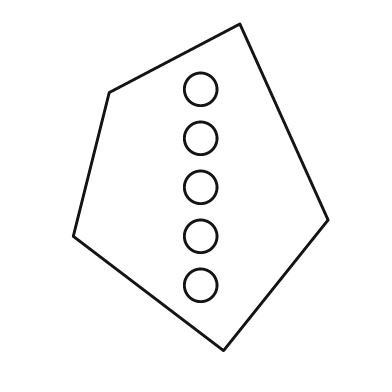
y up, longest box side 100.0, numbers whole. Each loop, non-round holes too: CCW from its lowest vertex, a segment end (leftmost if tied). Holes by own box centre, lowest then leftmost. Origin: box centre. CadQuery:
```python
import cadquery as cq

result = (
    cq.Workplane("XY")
    .moveTo(7.0, -50.0)
    .lineTo(39.0, -10.0)
    .lineTo(12.0, 50.0)
    .lineTo(-28.0, 29.0)
    .lineTo(-39.0, -15.0)
    .close()
    .moveTo(0.0, -30.0)
    .circle(5.0)
    .moveTo(0.0, -15.0)
    .circle(5.0)
    .moveTo(0.0, 0.0)
    .circle(5.0)
    .moveTo(0.0, 15.0)
    .circle(5.0)
    .moveTo(0.0, 30.0)
    .circle(5.0)
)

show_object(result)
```